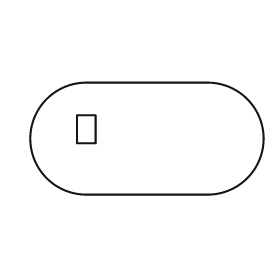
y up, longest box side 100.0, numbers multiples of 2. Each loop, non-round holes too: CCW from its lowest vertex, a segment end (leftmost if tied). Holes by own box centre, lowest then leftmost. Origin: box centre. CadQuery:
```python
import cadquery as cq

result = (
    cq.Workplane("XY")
    .moveTo(-26.0, -24.0)
    .lineTo(26.0, -24.0)
    .threePointArc((50.0, 0.0), (26.0, 24.0))
    .lineTo(-26.0, 24.0)
    .threePointArc((-50.0, 0.0), (-26.0, -24.0))
    .close()
    .moveTo(-30.0, -2.0)
    .lineTo(-22.0, -2.0)
    .lineTo(-22.0, 10.0)
    .lineTo(-30.0, 10.0)
    .close()
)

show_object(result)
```